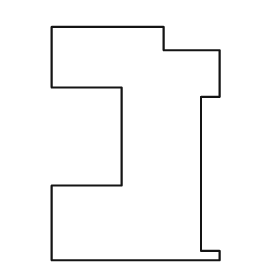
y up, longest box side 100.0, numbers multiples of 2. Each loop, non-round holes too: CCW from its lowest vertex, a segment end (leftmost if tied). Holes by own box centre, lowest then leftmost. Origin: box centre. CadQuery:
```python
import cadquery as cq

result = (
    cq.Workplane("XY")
    .moveTo(-36.0, -50.0)
    .lineTo(36.0, -50.0)
    .lineTo(36.0, -46.0)
    .lineTo(28.0, -46.0)
    .lineTo(28.0, 20.0)
    .lineTo(36.0, 20.0)
    .lineTo(36.0, 40.0)
    .lineTo(12.0, 40.0)
    .lineTo(12.0, 50.0)
    .lineTo(-36.0, 50.0)
    .lineTo(-36.0, 24.0)
    .lineTo(-6.0, 24.0)
    .lineTo(-6.0, -18.0)
    .lineTo(-36.0, -18.0)
    .close()
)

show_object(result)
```